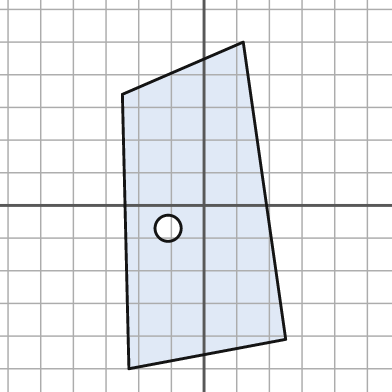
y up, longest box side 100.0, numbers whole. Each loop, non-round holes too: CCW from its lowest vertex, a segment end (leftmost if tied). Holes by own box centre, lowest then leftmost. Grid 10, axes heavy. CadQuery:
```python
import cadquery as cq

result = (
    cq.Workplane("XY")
    .moveTo(-23.0, -50.0)
    .lineTo(25.0, -41.0)
    .lineTo(12.0, 50.0)
    .lineTo(-25.0, 34.0)
    .close()
    .moveTo(-11.0, -7.0)
    .circle(4.0)
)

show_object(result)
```